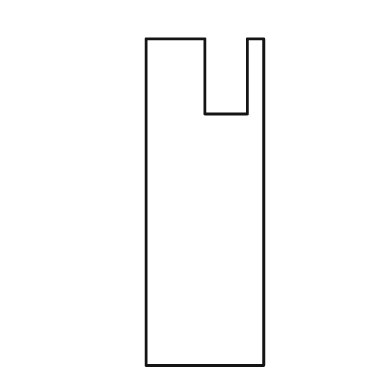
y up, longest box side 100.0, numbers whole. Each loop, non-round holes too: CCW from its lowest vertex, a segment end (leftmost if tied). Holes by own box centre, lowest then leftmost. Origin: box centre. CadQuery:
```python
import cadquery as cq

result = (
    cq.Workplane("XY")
    .moveTo(-18.0, -50.0)
    .lineTo(18.0, -50.0)
    .lineTo(18.0, 50.0)
    .lineTo(13.0, 50.0)
    .lineTo(13.0, 27.0)
    .lineTo(0.0, 27.0)
    .lineTo(0.0, 50.0)
    .lineTo(-18.0, 50.0)
    .close()
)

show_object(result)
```